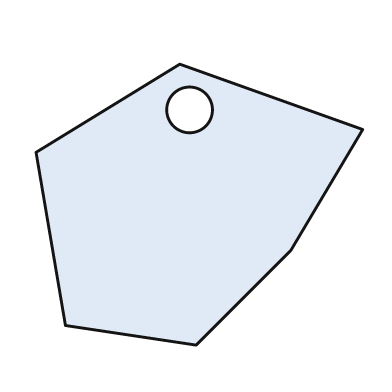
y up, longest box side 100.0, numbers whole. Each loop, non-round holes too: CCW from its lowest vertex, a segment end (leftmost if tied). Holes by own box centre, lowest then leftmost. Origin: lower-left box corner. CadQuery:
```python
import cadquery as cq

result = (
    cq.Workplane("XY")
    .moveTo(49.0, 0.0)
    .lineTo(78.0, 29.0)
    .lineTo(100.0, 66.0)
    .lineTo(44.0, 86.0)
    .lineTo(0.0, 59.0)
    .lineTo(9.0, 6.0)
    .close()
    .moveTo(47.0, 72.0)
    .circle(7.0)
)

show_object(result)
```